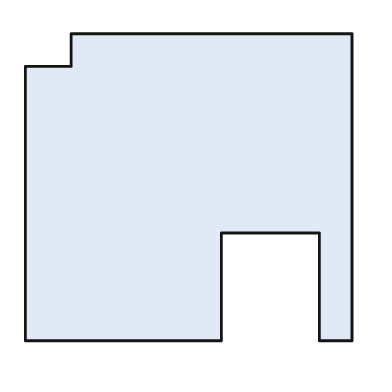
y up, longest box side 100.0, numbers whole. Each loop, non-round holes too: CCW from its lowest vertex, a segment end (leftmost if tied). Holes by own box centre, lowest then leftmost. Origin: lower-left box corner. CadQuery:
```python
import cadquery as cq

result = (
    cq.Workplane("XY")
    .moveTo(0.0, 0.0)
    .lineTo(60.0, 0.0)
    .lineTo(60.0, 33.0)
    .lineTo(90.0, 33.0)
    .lineTo(90.0, 0.0)
    .lineTo(100.0, 0.0)
    .lineTo(100.0, 94.0)
    .lineTo(14.0, 94.0)
    .lineTo(14.0, 84.0)
    .lineTo(0.0, 84.0)
    .close()
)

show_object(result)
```